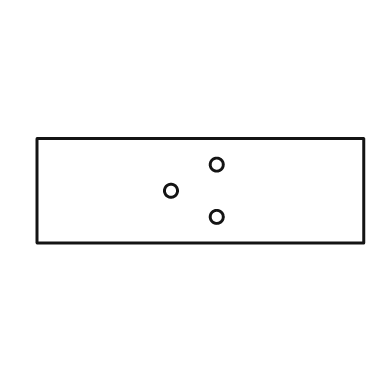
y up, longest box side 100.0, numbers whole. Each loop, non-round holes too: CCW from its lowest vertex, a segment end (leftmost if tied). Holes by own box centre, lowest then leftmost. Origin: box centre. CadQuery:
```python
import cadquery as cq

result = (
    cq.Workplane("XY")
    .moveTo(-50.0, -16.0)
    .lineTo(50.0, -16.0)
    .lineTo(50.0, 16.0)
    .lineTo(-50.0, 16.0)
    .close()
    .moveTo(5.0, -8.0)
    .circle(2.0)
    .moveTo(-9.0, 0.0)
    .circle(2.0)
    .moveTo(5.0, 8.0)
    .circle(2.0)
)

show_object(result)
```